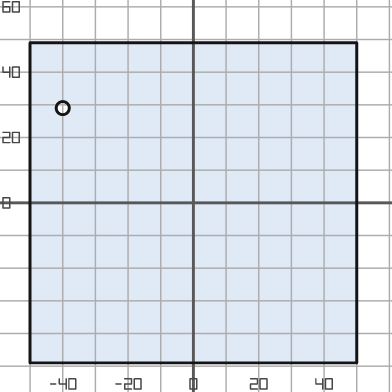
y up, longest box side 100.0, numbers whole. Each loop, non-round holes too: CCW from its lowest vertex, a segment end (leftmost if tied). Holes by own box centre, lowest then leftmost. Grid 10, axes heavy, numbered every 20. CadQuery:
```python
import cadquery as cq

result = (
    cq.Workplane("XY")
    .moveTo(-50.0, -49.0)
    .lineTo(50.0, -49.0)
    .lineTo(50.0, 49.0)
    .lineTo(-50.0, 49.0)
    .close()
    .moveTo(-40.0, 29.0)
    .circle(2.0)
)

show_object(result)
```